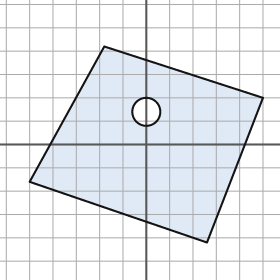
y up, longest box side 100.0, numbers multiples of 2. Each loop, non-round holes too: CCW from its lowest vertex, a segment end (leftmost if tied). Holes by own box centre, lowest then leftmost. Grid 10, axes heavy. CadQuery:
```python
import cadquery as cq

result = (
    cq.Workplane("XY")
    .moveTo(26.0, -42.0)
    .lineTo(50.0, 20.0)
    .lineTo(-18.0, 42.0)
    .lineTo(-50.0, -16.0)
    .close()
    .moveTo(0.0, 14.0)
    .circle(6.0)
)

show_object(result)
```